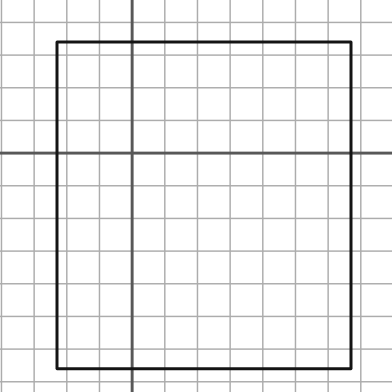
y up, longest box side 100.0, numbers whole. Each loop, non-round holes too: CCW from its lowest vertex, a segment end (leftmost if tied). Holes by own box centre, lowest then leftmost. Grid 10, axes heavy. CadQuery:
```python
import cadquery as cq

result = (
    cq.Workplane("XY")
    .moveTo(-23.0, -66.0)
    .lineTo(67.0, -66.0)
    .lineTo(67.0, 34.0)
    .lineTo(-23.0, 34.0)
    .close()
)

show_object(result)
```